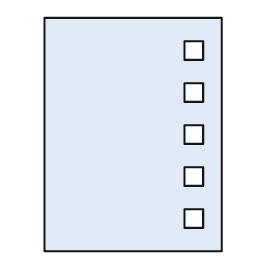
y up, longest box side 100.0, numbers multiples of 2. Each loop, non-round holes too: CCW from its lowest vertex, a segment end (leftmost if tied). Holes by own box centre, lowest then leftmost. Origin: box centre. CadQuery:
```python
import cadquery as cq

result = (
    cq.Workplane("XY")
    .moveTo(-38.0, -50.0)
    .lineTo(38.0, -50.0)
    .lineTo(38.0, 50.0)
    .lineTo(-38.0, 50.0)
    .close()
    .moveTo(22.0, -40.0)
    .lineTo(30.0, -40.0)
    .lineTo(30.0, -32.0)
    .lineTo(22.0, -32.0)
    .close()
    .moveTo(22.0, -22.0)
    .lineTo(30.0, -22.0)
    .lineTo(30.0, -14.0)
    .lineTo(22.0, -14.0)
    .close()
    .moveTo(22.0, -4.0)
    .lineTo(30.0, -4.0)
    .lineTo(30.0, 4.0)
    .lineTo(22.0, 4.0)
    .close()
    .moveTo(22.0, 14.0)
    .lineTo(30.0, 14.0)
    .lineTo(30.0, 22.0)
    .lineTo(22.0, 22.0)
    .close()
    .moveTo(22.0, 32.0)
    .lineTo(30.0, 32.0)
    .lineTo(30.0, 40.0)
    .lineTo(22.0, 40.0)
    .close()
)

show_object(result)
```